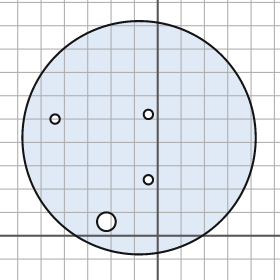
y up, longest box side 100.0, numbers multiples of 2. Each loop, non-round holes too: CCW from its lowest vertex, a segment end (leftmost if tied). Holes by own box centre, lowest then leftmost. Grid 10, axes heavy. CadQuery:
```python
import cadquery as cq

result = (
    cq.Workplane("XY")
    .moveTo(-8.0, 42.0)
    .circle(50.0)
    .moveTo(-22.0, 6.0)
    .circle(4.0)
    .moveTo(-4.0, 24.0)
    .circle(2.0)
    .moveTo(-44.0, 50.0)
    .circle(2.0)
    .moveTo(-4.0, 52.0)
    .circle(2.0)
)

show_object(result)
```